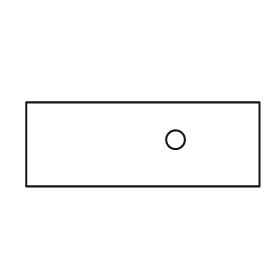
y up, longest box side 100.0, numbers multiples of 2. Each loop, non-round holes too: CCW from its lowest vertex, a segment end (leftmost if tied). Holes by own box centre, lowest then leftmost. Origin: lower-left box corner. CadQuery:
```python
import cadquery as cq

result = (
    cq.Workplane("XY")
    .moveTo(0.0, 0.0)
    .lineTo(100.0, 0.0)
    .lineTo(100.0, 36.0)
    .lineTo(0.0, 36.0)
    .close()
    .moveTo(64.0, 20.0)
    .circle(4.0)
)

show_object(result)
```